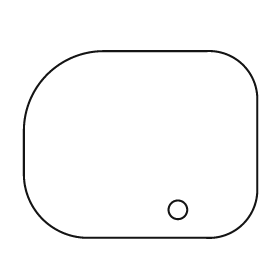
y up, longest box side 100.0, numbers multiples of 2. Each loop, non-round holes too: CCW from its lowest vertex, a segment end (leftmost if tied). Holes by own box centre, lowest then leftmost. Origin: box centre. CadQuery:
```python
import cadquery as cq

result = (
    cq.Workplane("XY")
    .moveTo(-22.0, -40.0)
    .lineTo(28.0, -40.0)
    .threePointArc((44.0, -34.0), (50.0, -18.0))
    .lineTo(50.0, 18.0)
    .threePointArc((44.0, 34.0), (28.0, 40.0))
    .lineTo(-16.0, 40.0)
    .threePointArc((-40.0, 30.0), (-50.0, 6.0))
    .lineTo(-50.0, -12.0)
    .threePointArc((-42.0, -32.0), (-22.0, -40.0))
    .close()
    .moveTo(16.0, -28.0)
    .circle(4.0)
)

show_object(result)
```